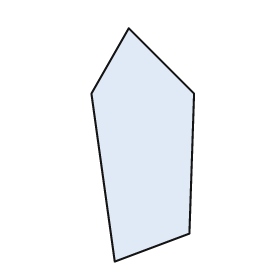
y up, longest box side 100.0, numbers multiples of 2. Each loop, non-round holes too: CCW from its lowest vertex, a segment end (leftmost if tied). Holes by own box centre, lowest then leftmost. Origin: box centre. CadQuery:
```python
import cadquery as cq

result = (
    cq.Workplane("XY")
    .moveTo(-12.0, -50.0)
    .lineTo(20.0, -38.0)
    .lineTo(22.0, 22.0)
    .lineTo(-6.0, 50.0)
    .lineTo(-22.0, 22.0)
    .close()
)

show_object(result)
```